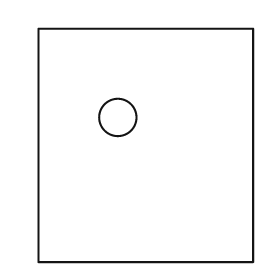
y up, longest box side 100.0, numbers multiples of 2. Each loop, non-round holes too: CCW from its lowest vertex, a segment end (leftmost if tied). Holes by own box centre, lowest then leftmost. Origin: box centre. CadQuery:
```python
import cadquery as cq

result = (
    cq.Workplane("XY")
    .moveTo(-46.0, -50.0)
    .lineTo(46.0, -50.0)
    .lineTo(46.0, 50.0)
    .lineTo(-46.0, 50.0)
    .close()
    .moveTo(-12.0, 12.0)
    .circle(8.0)
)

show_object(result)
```